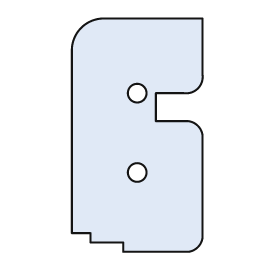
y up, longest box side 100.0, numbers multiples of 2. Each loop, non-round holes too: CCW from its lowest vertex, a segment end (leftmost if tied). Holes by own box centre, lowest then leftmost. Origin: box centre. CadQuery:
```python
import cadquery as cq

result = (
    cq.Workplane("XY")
    .moveTo(-6.0, -50.0)
    .lineTo(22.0, -50.0)
    .threePointArc((26.0, -48.0), (28.0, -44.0))
    .lineTo(28.0, 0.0)
    .threePointArc((26.0, 4.0), (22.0, 6.0))
    .lineTo(8.0, 6.0)
    .lineTo(8.0, 18.0)
    .lineTo(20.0, 18.0)
    .threePointArc((26.0, 20.0), (28.0, 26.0))
    .lineTo(28.0, 50.0)
    .lineTo(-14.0, 50.0)
    .threePointArc((-24.0, 46.0), (-28.0, 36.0))
    .lineTo(-28.0, -42.0)
    .lineTo(-20.0, -42.0)
    .lineTo(-20.0, -46.0)
    .lineTo(-6.0, -46.0)
    .close()
    .moveTo(0.0, -16.0)
    .circle(4.0)
    .moveTo(0.0, 18.0)
    .circle(4.0)
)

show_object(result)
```